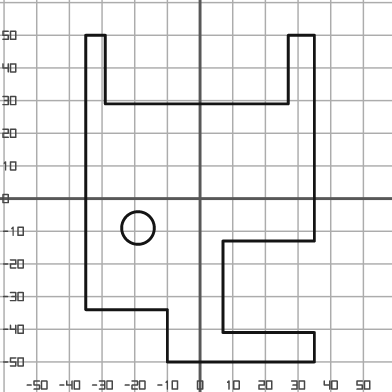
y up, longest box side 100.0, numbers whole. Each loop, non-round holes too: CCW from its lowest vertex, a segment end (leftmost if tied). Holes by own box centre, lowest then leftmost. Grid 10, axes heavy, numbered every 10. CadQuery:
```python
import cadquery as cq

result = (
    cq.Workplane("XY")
    .moveTo(-10.0, -50.0)
    .lineTo(35.0, -50.0)
    .lineTo(35.0, -41.0)
    .lineTo(7.0, -41.0)
    .lineTo(7.0, -13.0)
    .lineTo(35.0, -13.0)
    .lineTo(35.0, 50.0)
    .lineTo(27.0, 50.0)
    .lineTo(27.0, 29.0)
    .lineTo(-29.0, 29.0)
    .lineTo(-29.0, 50.0)
    .lineTo(-35.0, 50.0)
    .lineTo(-35.0, -34.0)
    .lineTo(-10.0, -34.0)
    .close()
    .moveTo(-19.0, -9.0)
    .circle(5.0)
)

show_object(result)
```